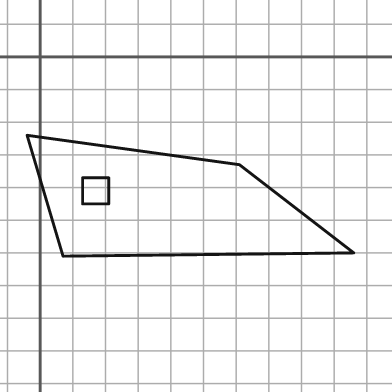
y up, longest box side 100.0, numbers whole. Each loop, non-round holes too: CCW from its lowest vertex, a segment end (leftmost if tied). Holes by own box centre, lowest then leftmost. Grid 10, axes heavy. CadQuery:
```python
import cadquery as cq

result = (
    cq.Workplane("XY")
    .moveTo(7.0, -61.0)
    .lineTo(96.0, -60.0)
    .lineTo(61.0, -33.0)
    .lineTo(-4.0, -24.0)
    .close()
    .moveTo(13.0, -45.0)
    .lineTo(21.0, -45.0)
    .lineTo(21.0, -37.0)
    .lineTo(13.0, -37.0)
    .close()
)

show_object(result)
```